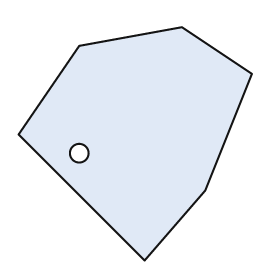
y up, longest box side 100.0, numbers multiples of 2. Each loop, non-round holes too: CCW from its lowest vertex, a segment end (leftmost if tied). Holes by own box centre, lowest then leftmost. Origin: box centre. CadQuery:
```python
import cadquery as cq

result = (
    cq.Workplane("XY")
    .moveTo(4.0, -50.0)
    .lineTo(30.0, -20.0)
    .lineTo(50.0, 30.0)
    .lineTo(20.0, 50.0)
    .lineTo(-24.0, 42.0)
    .lineTo(-50.0, 4.0)
    .close()
    .moveTo(-24.0, -4.0)
    .circle(4.0)
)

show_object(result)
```